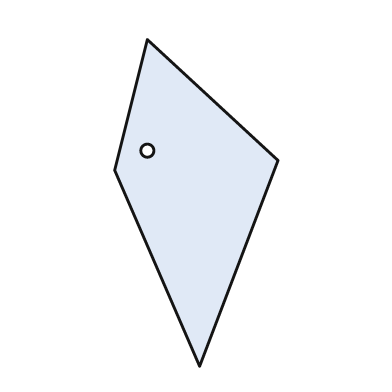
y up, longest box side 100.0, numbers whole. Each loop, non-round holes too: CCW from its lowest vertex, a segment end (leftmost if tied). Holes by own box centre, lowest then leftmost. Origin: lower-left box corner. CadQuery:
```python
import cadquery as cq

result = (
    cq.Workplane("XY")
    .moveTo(26.0, 0.0)
    .lineTo(50.0, 63.0)
    .lineTo(10.0, 100.0)
    .lineTo(0.0, 60.0)
    .close()
    .moveTo(10.0, 66.0)
    .circle(2.0)
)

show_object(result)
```